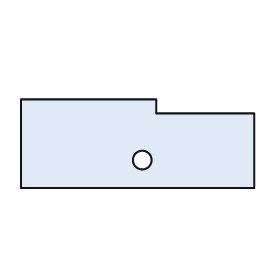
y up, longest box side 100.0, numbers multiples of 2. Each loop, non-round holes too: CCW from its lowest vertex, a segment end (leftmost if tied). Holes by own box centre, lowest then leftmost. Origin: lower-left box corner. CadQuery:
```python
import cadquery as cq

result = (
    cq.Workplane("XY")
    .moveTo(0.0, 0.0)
    .lineTo(100.0, 0.0)
    .lineTo(100.0, 32.0)
    .lineTo(58.0, 32.0)
    .lineTo(58.0, 38.0)
    .lineTo(0.0, 38.0)
    .close()
    .moveTo(52.0, 12.0)
    .circle(4.0)
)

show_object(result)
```